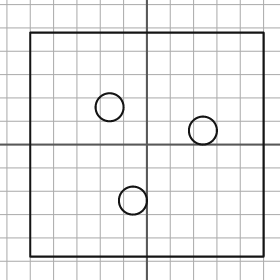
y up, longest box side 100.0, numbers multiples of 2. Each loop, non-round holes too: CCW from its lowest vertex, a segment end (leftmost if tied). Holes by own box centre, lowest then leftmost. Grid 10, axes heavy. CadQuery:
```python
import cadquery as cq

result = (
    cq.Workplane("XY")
    .moveTo(-50.0, -48.0)
    .lineTo(50.0, -48.0)
    .lineTo(50.0, 48.0)
    .lineTo(-50.0, 48.0)
    .close()
    .moveTo(-6.0, -24.0)
    .circle(6.0)
    .moveTo(24.0, 6.0)
    .circle(6.0)
    .moveTo(-16.0, 16.0)
    .circle(6.0)
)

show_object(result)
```